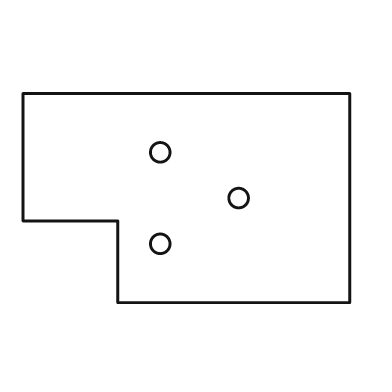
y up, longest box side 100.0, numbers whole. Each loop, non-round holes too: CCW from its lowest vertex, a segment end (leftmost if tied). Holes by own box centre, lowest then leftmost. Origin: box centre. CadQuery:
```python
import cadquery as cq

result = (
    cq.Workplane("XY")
    .moveTo(-21.0, -32.0)
    .lineTo(50.0, -32.0)
    .lineTo(50.0, 32.0)
    .lineTo(-50.0, 32.0)
    .lineTo(-50.0, -7.0)
    .lineTo(-21.0, -7.0)
    .close()
    .moveTo(-8.0, -14.0)
    .circle(3.0)
    .moveTo(16.0, 0.0)
    .circle(3.0)
    .moveTo(-8.0, 14.0)
    .circle(3.0)
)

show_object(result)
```